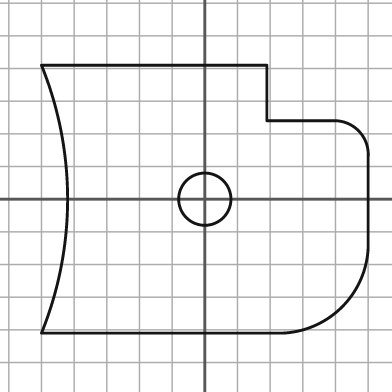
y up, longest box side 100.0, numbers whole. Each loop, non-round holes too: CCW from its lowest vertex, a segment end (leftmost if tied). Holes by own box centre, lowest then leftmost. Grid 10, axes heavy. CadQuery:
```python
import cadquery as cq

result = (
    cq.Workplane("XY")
    .moveTo(-50.0, -41.0)
    .lineTo(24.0, -41.0)
    .threePointArc((42.0, -33.0), (50.0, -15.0))
    .lineTo(50.0, 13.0)
    .threePointArc((47.0, 21.0), (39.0, 24.0))
    .lineTo(19.0, 24.0)
    .lineTo(19.0, 41.0)
    .lineTo(-50.0, 41.0)
    .threePointArc((-42.0, 0.0), (-50.0, -41.0))
    .close()
    .moveTo(0.0, 0.0)
    .circle(8.0)
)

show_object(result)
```